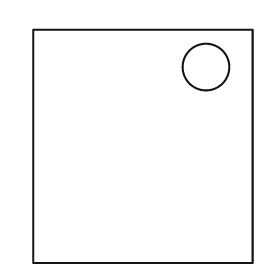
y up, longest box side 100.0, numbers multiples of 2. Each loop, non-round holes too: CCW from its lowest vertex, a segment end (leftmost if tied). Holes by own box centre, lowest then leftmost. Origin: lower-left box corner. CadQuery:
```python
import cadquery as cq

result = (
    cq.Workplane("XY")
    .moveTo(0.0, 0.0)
    .lineTo(94.0, 0.0)
    .lineTo(94.0, 100.0)
    .lineTo(0.0, 100.0)
    .close()
    .moveTo(74.0, 84.0)
    .circle(10.0)
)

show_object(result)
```